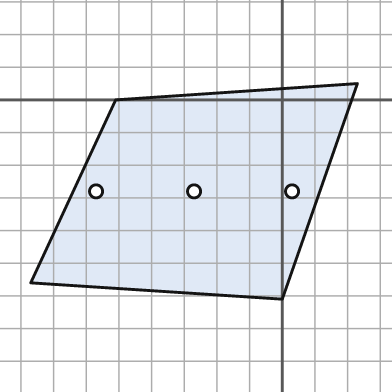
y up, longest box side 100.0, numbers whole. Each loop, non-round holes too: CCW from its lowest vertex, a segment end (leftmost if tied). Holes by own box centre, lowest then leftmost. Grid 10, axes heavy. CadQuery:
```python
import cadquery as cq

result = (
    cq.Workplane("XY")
    .moveTo(0.0, -61.0)
    .lineTo(23.0, 5.0)
    .lineTo(-51.0, 0.0)
    .lineTo(-77.0, -56.0)
    .close()
    .moveTo(-57.0, -28.0)
    .circle(2.0)
    .moveTo(-27.0, -28.0)
    .circle(2.0)
    .moveTo(3.0, -28.0)
    .circle(2.0)
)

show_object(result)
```